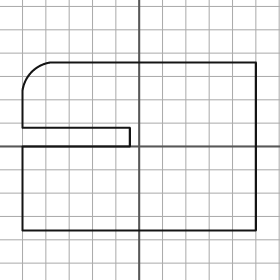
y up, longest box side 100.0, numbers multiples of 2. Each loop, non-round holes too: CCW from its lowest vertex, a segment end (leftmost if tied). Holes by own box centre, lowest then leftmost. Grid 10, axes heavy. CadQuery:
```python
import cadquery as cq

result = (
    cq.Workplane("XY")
    .moveTo(-50.0, -36.0)
    .lineTo(50.0, -36.0)
    .lineTo(50.0, 36.0)
    .lineTo(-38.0, 36.0)
    .threePointArc((-46.0, 32.0), (-50.0, 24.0))
    .lineTo(-50.0, 8.0)
    .lineTo(-4.0, 8.0)
    .lineTo(-4.0, 0.0)
    .lineTo(-50.0, 0.0)
    .close()
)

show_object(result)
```